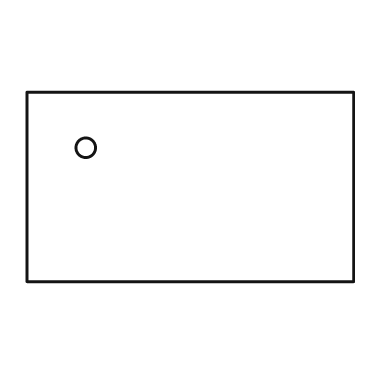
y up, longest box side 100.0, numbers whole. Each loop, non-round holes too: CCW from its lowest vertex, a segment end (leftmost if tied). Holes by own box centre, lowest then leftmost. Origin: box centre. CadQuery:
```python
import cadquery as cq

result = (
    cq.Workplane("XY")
    .moveTo(-50.0, -29.0)
    .lineTo(50.0, -29.0)
    .lineTo(50.0, 29.0)
    .lineTo(-50.0, 29.0)
    .close()
    .moveTo(-32.0, 12.0)
    .circle(3.0)
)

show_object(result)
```